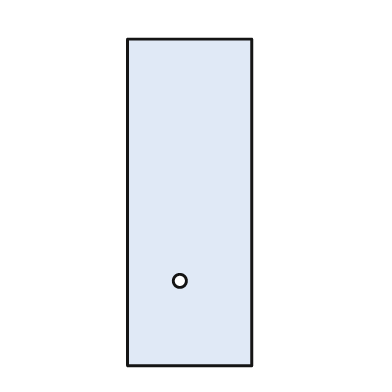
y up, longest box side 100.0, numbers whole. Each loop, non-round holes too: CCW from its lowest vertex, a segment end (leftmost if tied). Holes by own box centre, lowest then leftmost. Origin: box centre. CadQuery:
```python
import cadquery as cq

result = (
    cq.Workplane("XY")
    .moveTo(-19.0, -50.0)
    .lineTo(19.0, -50.0)
    .lineTo(19.0, 50.0)
    .lineTo(-19.0, 50.0)
    .close()
    .moveTo(-3.0, -24.0)
    .circle(2.0)
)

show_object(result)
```